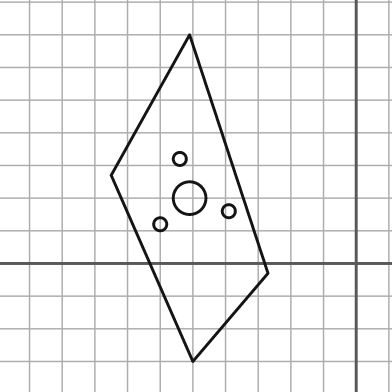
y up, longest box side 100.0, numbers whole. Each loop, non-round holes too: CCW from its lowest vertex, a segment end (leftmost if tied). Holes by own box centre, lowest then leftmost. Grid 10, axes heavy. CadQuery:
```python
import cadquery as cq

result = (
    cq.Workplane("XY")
    .moveTo(-50.0, -30.0)
    .lineTo(-27.0, -3.0)
    .lineTo(-51.0, 70.0)
    .lineTo(-75.0, 27.0)
    .close()
    .moveTo(-60.0, 12.0)
    .circle(2.0)
    .moveTo(-39.0, 16.0)
    .circle(2.0)
    .moveTo(-51.0, 20.0)
    .circle(5.0)
    .moveTo(-54.0, 32.0)
    .circle(2.0)
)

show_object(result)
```